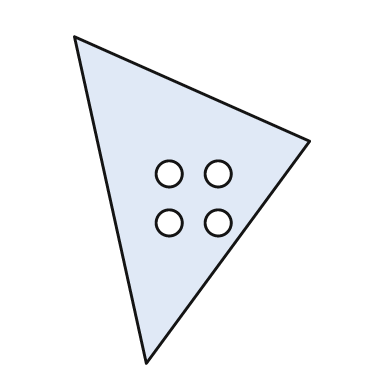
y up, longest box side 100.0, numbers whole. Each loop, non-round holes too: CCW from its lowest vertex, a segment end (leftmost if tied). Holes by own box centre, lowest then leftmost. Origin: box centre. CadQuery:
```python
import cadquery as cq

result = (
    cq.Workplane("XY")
    .moveTo(-14.0, -50.0)
    .lineTo(36.0, 18.0)
    .lineTo(-36.0, 50.0)
    .close()
    .moveTo(-7.0, -7.0)
    .circle(4.0)
    .moveTo(8.0, -7.0)
    .circle(4.0)
    .moveTo(-7.0, 8.0)
    .circle(4.0)
    .moveTo(8.0, 8.0)
    .circle(4.0)
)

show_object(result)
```